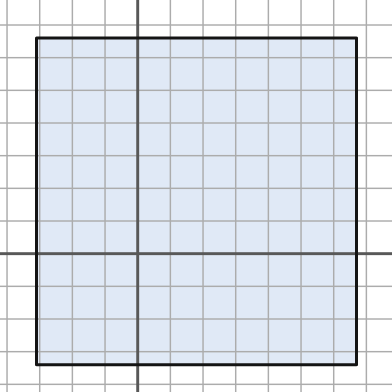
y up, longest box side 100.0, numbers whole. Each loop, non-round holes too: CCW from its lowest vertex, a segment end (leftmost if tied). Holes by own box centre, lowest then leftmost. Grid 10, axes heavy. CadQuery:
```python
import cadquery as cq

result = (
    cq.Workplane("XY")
    .moveTo(-31.0, -34.0)
    .lineTo(67.0, -34.0)
    .lineTo(67.0, 66.0)
    .lineTo(-31.0, 66.0)
    .close()
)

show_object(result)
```